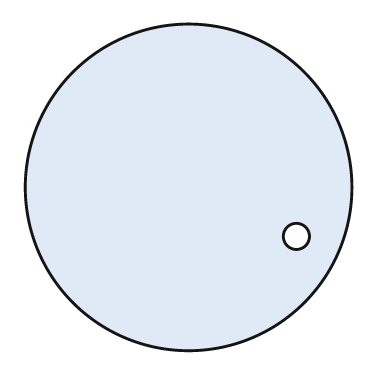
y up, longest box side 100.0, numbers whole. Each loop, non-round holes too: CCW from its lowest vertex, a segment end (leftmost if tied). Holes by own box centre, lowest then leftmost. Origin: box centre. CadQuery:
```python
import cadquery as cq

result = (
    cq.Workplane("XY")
    .moveTo(0.0, 0.0)
    .circle(50.0)
    .moveTo(33.0, -15.0)
    .circle(4.0)
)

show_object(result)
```